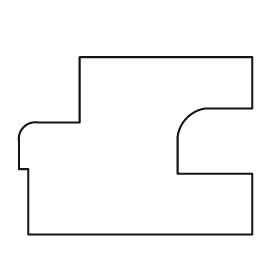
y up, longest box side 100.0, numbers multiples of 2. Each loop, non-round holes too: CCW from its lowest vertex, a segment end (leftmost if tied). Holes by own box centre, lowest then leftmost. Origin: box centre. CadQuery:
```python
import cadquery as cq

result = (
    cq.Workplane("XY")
    .moveTo(-46.0, -38.0)
    .lineTo(50.0, -38.0)
    .lineTo(50.0, -12.0)
    .lineTo(18.0, -12.0)
    .lineTo(18.0, 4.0)
    .threePointArc((22.0, 12.0), (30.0, 16.0))
    .lineTo(50.0, 16.0)
    .lineTo(50.0, 38.0)
    .lineTo(-24.0, 38.0)
    .lineTo(-24.0, 10.0)
    .lineTo(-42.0, 10.0)
    .threePointArc((-48.0, 8.0), (-50.0, 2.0))
    .lineTo(-50.0, -10.0)
    .lineTo(-46.0, -10.0)
    .close()
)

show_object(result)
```